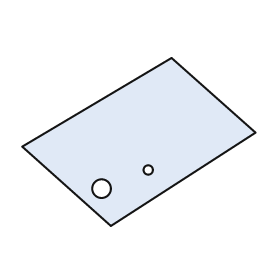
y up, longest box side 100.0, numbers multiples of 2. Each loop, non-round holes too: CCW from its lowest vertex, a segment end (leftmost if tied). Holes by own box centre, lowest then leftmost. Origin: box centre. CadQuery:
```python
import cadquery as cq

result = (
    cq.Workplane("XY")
    .moveTo(-12.0, -36.0)
    .lineTo(50.0, 4.0)
    .lineTo(14.0, 36.0)
    .lineTo(-50.0, -2.0)
    .close()
    .moveTo(-16.0, -20.0)
    .circle(4.0)
    .moveTo(4.0, -12.0)
    .circle(2.0)
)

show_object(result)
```